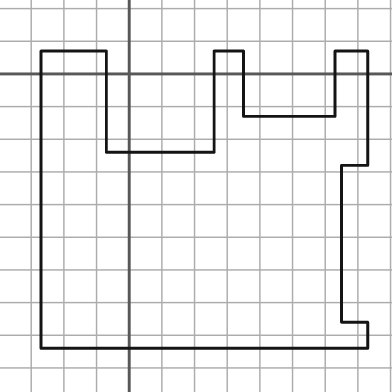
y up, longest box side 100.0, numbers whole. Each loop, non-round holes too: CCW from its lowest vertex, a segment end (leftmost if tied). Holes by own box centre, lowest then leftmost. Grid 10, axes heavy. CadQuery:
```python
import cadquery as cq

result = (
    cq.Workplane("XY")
    .moveTo(-27.0, -84.0)
    .lineTo(73.0, -84.0)
    .lineTo(73.0, -76.0)
    .lineTo(65.0, -76.0)
    .lineTo(65.0, -28.0)
    .lineTo(73.0, -28.0)
    .lineTo(73.0, 7.0)
    .lineTo(63.0, 7.0)
    .lineTo(63.0, -13.0)
    .lineTo(35.0, -13.0)
    .lineTo(35.0, 7.0)
    .lineTo(26.0, 7.0)
    .lineTo(26.0, -24.0)
    .lineTo(-7.0, -24.0)
    .lineTo(-7.0, 7.0)
    .lineTo(-27.0, 7.0)
    .close()
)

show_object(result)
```